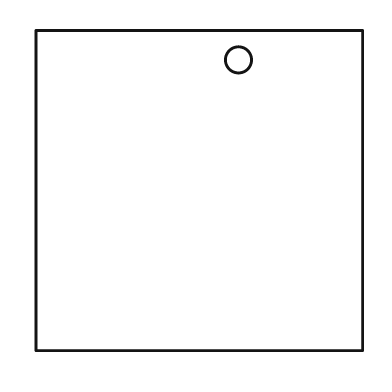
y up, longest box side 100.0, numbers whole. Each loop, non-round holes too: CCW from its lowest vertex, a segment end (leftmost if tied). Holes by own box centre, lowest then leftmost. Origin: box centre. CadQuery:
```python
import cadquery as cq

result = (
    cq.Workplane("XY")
    .moveTo(-50.0, -49.0)
    .lineTo(50.0, -49.0)
    .lineTo(50.0, 49.0)
    .lineTo(-50.0, 49.0)
    .close()
    .moveTo(12.0, 40.0)
    .circle(4.0)
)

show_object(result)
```